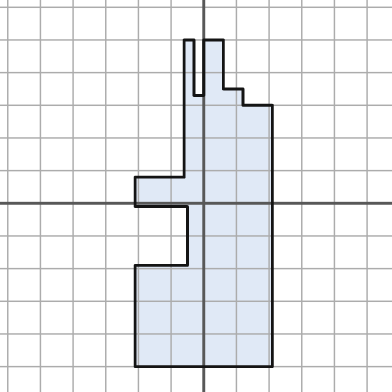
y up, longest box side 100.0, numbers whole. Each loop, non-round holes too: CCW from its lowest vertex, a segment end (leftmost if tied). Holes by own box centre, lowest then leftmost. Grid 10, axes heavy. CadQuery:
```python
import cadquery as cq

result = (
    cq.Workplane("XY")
    .moveTo(-21.0, -50.0)
    .lineTo(21.0, -50.0)
    .lineTo(21.0, 30.0)
    .lineTo(12.0, 30.0)
    .lineTo(12.0, 35.0)
    .lineTo(6.0, 35.0)
    .lineTo(6.0, 50.0)
    .lineTo(0.0, 50.0)
    .lineTo(0.0, 33.0)
    .lineTo(-3.0, 33.0)
    .lineTo(-3.0, 50.0)
    .lineTo(-6.0, 50.0)
    .lineTo(-6.0, 8.0)
    .lineTo(-21.0, 8.0)
    .lineTo(-21.0, -1.0)
    .lineTo(-5.0, -1.0)
    .lineTo(-5.0, -19.0)
    .lineTo(-21.0, -19.0)
    .close()
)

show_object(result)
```